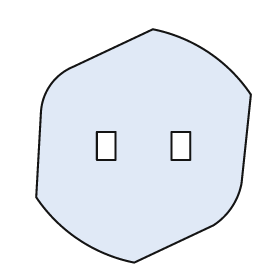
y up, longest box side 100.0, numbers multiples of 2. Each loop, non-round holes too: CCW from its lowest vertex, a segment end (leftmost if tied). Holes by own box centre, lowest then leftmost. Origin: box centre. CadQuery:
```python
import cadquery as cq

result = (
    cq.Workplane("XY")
    .moveTo(-4.0, -50.0)
    .lineTo(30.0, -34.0)
    .threePointArc((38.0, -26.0), (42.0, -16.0))
    .lineTo(46.0, 22.0)
    .threePointArc((28.0, 40.0), (4.0, 50.0))
    .lineTo(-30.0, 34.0)
    .threePointArc((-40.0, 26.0), (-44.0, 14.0))
    .lineTo(-46.0, -22.0)
    .threePointArc((-28.0, -40.0), (-4.0, -50.0))
    .close()
    .moveTo(-20.0, -6.0)
    .lineTo(-12.0, -6.0)
    .lineTo(-12.0, 6.0)
    .lineTo(-20.0, 6.0)
    .close()
    .moveTo(12.0, -6.0)
    .lineTo(20.0, -6.0)
    .lineTo(20.0, 6.0)
    .lineTo(12.0, 6.0)
    .close()
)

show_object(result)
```